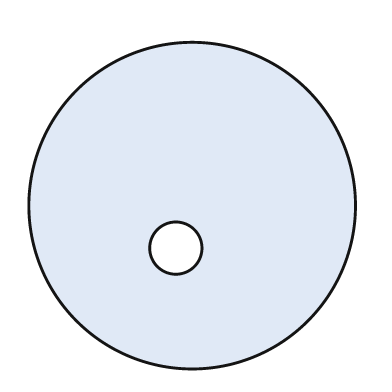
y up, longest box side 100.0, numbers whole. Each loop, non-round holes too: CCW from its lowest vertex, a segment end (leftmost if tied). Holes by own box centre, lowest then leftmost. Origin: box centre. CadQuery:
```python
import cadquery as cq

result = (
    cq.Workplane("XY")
    .moveTo(0.0, 0.0)
    .circle(50.0)
    .moveTo(-5.0, -13.0)
    .circle(8.0)
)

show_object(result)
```